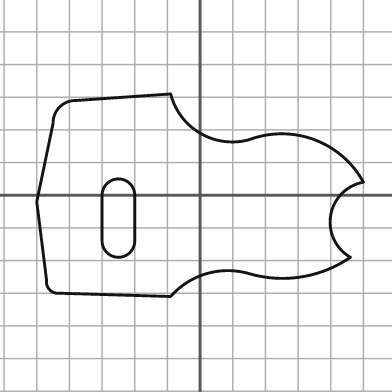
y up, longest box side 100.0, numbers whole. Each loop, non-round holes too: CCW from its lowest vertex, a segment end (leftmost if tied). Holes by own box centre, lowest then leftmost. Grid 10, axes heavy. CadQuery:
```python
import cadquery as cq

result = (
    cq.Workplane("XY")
    .moveTo(-9.0, -31.0)
    .threePointArc((2.0, -24.0), (15.0, -24.0))
    .threePointArc((31.0, -25.0), (46.0, -19.0))
    .threePointArc((40.0, -6.0), (50.0, 4.0))
    .threePointArc((35.0, 17.0), (15.0, 17.0))
    .threePointArc((0.0, 19.0), (-9.0, 31.0))
    .lineTo(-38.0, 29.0)
    .threePointArc((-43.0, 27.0), (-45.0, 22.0))
    .lineTo(-50.0, -2.0)
    .lineTo(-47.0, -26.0)
    .threePointArc((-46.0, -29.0), (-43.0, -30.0))
    .close()
    .moveTo(-30.0, -14.0)
    .threePointArc((-25.0, -19.0), (-20.0, -14.0))
    .lineTo(-20.0, 0.0)
    .threePointArc((-25.0, 5.0), (-30.0, 0.0))
    .close()
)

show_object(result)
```